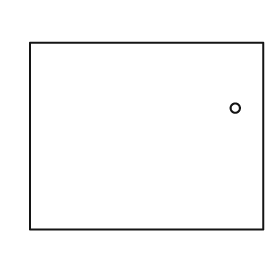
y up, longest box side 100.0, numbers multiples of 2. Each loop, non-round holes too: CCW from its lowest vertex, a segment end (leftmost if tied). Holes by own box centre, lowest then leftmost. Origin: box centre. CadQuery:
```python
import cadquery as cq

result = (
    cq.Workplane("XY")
    .moveTo(-50.0, -40.0)
    .lineTo(50.0, -40.0)
    .lineTo(50.0, 40.0)
    .lineTo(-50.0, 40.0)
    .close()
    .moveTo(38.0, 12.0)
    .circle(2.0)
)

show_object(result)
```